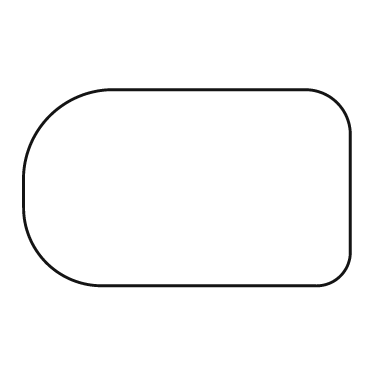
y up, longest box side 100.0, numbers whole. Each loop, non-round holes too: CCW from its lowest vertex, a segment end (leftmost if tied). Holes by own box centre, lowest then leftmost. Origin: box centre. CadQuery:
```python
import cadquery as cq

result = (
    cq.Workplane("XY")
    .moveTo(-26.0, -30.0)
    .lineTo(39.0, -30.0)
    .threePointArc((47.0, -27.0), (50.0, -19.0))
    .lineTo(50.0, 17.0)
    .threePointArc((46.0, 26.0), (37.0, 30.0))
    .lineTo(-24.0, 30.0)
    .threePointArc((-42.0, 22.0), (-50.0, 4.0))
    .lineTo(-50.0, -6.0)
    .threePointArc((-43.0, -23.0), (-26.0, -30.0))
    .close()
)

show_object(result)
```